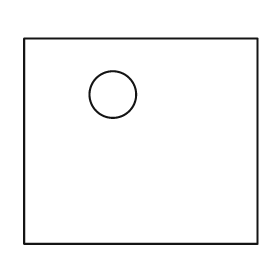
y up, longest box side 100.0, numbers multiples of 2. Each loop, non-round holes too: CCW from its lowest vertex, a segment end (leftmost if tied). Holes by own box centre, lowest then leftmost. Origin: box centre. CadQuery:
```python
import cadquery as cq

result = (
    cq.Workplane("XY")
    .moveTo(-50.0, -44.0)
    .lineTo(50.0, -44.0)
    .lineTo(50.0, 44.0)
    .lineTo(-50.0, 44.0)
    .close()
    .moveTo(-12.0, 20.0)
    .circle(10.0)
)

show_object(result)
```